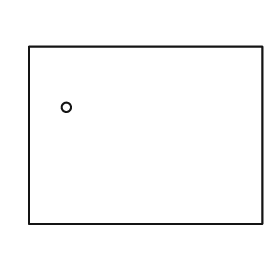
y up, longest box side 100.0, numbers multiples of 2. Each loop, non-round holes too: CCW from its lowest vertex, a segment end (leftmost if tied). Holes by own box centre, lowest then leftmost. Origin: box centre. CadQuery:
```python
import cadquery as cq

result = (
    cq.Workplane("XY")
    .moveTo(-50.0, -38.0)
    .lineTo(50.0, -38.0)
    .lineTo(50.0, 38.0)
    .lineTo(-50.0, 38.0)
    .close()
    .moveTo(-34.0, 12.0)
    .circle(2.0)
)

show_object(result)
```